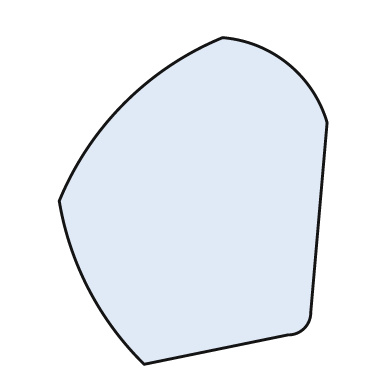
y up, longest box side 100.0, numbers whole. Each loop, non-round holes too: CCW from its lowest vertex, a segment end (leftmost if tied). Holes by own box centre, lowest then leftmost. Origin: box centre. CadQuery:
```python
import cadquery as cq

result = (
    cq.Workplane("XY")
    .moveTo(-15.0, -50.0)
    .lineTo(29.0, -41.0)
    .threePointArc((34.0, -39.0), (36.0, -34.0))
    .lineTo(41.0, 24.0)
    .threePointArc((29.0, 42.0), (9.0, 50.0))
    .threePointArc((-21.0, 30.0), (-41.0, 0.0))
    .threePointArc((-32.0, -27.0), (-15.0, -50.0))
    .close()
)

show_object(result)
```